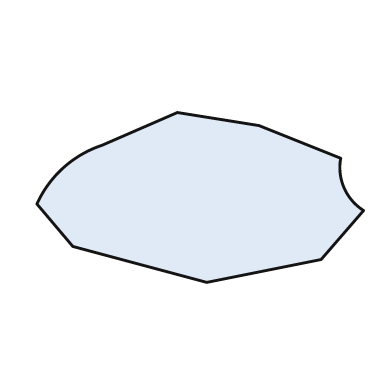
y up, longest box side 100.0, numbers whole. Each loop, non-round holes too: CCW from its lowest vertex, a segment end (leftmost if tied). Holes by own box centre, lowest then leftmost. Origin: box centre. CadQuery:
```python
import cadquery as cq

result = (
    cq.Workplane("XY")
    .moveTo(2.0, -26.0)
    .lineTo(37.0, -19.0)
    .lineTo(50.0, -4.0)
    .threePointArc((44.0, 3.0), (43.0, 12.0))
    .lineTo(18.0, 22.0)
    .lineTo(-7.0, 26.0)
    .lineTo(-30.0, 16.0)
    .threePointArc((-42.0, 9.0), (-50.0, -2.0))
    .lineTo(-39.0, -15.0)
    .close()
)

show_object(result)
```